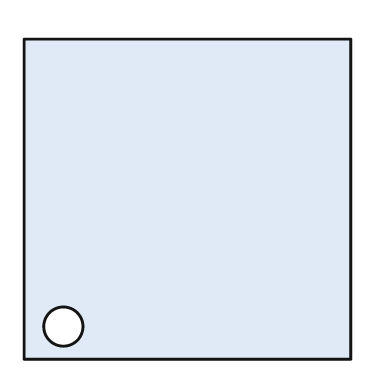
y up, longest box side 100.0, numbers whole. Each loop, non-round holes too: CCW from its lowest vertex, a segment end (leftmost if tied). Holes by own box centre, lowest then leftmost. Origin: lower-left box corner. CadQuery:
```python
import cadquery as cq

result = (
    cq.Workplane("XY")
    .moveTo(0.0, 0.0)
    .lineTo(100.0, 0.0)
    .lineTo(100.0, 98.0)
    .lineTo(0.0, 98.0)
    .close()
    .moveTo(12.0, 10.0)
    .circle(6.0)
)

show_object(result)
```